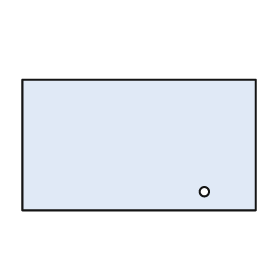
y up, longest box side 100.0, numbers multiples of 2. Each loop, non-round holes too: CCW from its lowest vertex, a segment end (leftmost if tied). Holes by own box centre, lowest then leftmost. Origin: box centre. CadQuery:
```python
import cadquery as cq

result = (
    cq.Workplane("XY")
    .moveTo(-50.0, -28.0)
    .lineTo(50.0, -28.0)
    .lineTo(50.0, 28.0)
    .lineTo(-50.0, 28.0)
    .close()
    .moveTo(28.0, -20.0)
    .circle(2.0)
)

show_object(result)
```